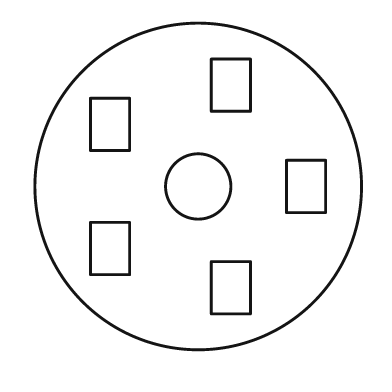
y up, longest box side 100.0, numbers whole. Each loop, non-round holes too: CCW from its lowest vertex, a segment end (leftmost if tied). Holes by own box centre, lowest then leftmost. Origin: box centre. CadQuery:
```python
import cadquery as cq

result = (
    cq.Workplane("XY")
    .moveTo(0.0, 0.0)
    .circle(50.0)
    .moveTo(4.0, -39.0)
    .lineTo(16.0, -39.0)
    .lineTo(16.0, -23.0)
    .lineTo(4.0, -23.0)
    .close()
    .moveTo(-33.0, -27.0)
    .lineTo(-21.0, -27.0)
    .lineTo(-21.0, -11.0)
    .lineTo(-33.0, -11.0)
    .close()
    .moveTo(0.0, 0.0)
    .circle(10.0)
    .moveTo(27.0, -8.0)
    .lineTo(39.0, -8.0)
    .lineTo(39.0, 8.0)
    .lineTo(27.0, 8.0)
    .close()
    .moveTo(-33.0, 11.0)
    .lineTo(-21.0, 11.0)
    .lineTo(-21.0, 27.0)
    .lineTo(-33.0, 27.0)
    .close()
    .moveTo(4.0, 23.0)
    .lineTo(16.0, 23.0)
    .lineTo(16.0, 39.0)
    .lineTo(4.0, 39.0)
    .close()
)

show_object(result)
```